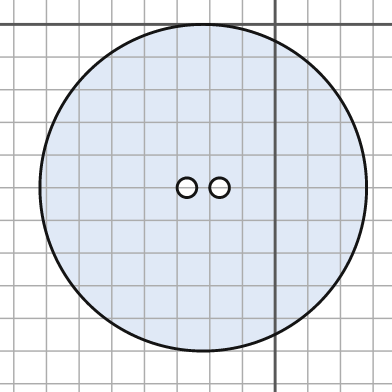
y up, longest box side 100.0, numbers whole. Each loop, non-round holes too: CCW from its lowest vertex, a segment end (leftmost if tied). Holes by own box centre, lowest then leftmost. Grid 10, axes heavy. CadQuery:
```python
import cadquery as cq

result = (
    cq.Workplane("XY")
    .moveTo(-22.0, -50.0)
    .circle(50.0)
    .moveTo(-27.0, -50.0)
    .circle(3.0)
    .moveTo(-17.0, -50.0)
    .circle(3.0)
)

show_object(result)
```